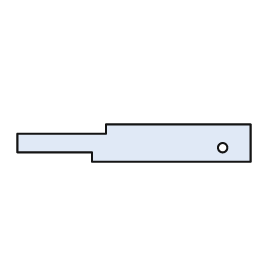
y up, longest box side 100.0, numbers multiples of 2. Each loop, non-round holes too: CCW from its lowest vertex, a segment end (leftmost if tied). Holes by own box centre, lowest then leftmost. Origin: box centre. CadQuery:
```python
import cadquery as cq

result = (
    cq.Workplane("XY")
    .moveTo(-18.0, -8.0)
    .lineTo(50.0, -8.0)
    .lineTo(50.0, 8.0)
    .lineTo(-12.0, 8.0)
    .lineTo(-12.0, 4.0)
    .lineTo(-50.0, 4.0)
    .lineTo(-50.0, -4.0)
    .lineTo(-18.0, -4.0)
    .close()
    .moveTo(38.0, -2.0)
    .circle(2.0)
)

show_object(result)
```